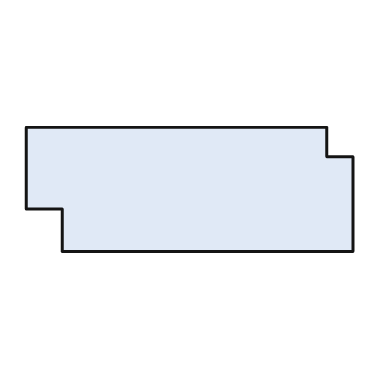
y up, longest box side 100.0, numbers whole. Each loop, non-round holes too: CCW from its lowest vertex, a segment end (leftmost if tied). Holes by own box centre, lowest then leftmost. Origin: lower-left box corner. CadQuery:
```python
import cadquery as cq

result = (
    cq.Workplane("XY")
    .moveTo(11.0, 0.0)
    .lineTo(100.0, 0.0)
    .lineTo(100.0, 29.0)
    .lineTo(92.0, 29.0)
    .lineTo(92.0, 38.0)
    .lineTo(0.0, 38.0)
    .lineTo(0.0, 13.0)
    .lineTo(11.0, 13.0)
    .close()
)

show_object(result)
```